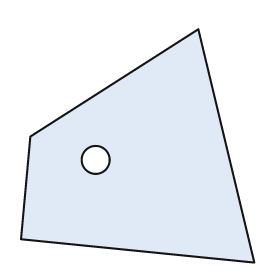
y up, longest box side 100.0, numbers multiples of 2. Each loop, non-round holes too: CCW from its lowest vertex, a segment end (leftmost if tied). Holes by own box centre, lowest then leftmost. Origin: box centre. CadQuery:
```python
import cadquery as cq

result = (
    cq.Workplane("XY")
    .moveTo(50.0, -50.0)
    .lineTo(26.0, 50.0)
    .lineTo(-46.0, 4.0)
    .lineTo(-50.0, -40.0)
    .close()
    .moveTo(-18.0, -6.0)
    .circle(6.0)
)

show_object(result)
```